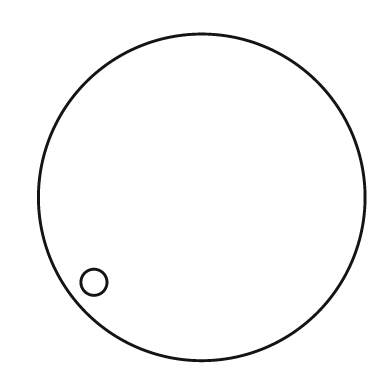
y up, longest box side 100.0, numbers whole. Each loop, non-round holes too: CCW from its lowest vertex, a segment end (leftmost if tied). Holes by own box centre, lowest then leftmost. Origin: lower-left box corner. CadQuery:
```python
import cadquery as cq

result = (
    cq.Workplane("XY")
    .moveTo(50.0, 50.0)
    .circle(50.0)
    .moveTo(17.0, 24.0)
    .circle(4.0)
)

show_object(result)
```